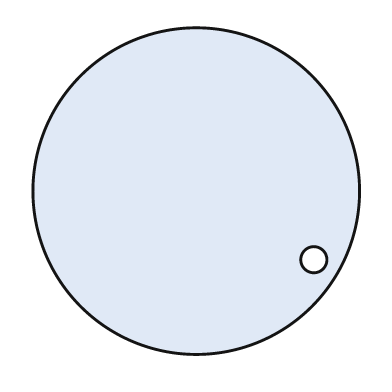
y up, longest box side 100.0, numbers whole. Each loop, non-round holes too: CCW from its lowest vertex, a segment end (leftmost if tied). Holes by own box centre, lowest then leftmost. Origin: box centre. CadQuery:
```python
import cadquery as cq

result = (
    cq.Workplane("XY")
    .moveTo(0.0, 0.0)
    .circle(50.0)
    .moveTo(36.0, -21.0)
    .circle(4.0)
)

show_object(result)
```